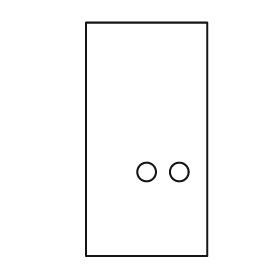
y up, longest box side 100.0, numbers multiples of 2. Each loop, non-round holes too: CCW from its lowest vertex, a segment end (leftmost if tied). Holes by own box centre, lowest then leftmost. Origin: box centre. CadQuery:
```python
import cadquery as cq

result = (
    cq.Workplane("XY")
    .moveTo(-26.0, -50.0)
    .lineTo(26.0, -50.0)
    .lineTo(26.0, 50.0)
    .lineTo(-26.0, 50.0)
    .close()
    .moveTo(0.0, -14.0)
    .circle(4.0)
    .moveTo(14.0, -14.0)
    .circle(4.0)
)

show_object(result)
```